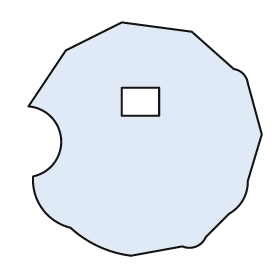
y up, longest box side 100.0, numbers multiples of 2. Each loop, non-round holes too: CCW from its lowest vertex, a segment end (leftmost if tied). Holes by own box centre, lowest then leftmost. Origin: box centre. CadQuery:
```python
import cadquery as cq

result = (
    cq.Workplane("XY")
    .moveTo(-6.0, -50.0)
    .lineTo(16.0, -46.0)
    .threePointArc((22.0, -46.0), (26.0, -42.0))
    .lineTo(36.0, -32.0)
    .threePointArc((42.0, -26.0), (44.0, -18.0))
    .lineTo(50.0, 2.0)
    .lineTo(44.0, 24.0)
    .threePointArc((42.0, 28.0), (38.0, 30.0))
    .lineTo(20.0, 46.0)
    .lineTo(-10.0, 50.0)
    .lineTo(-34.0, 38.0)
    .lineTo(-50.0, 14.0)
    .threePointArc((-36.0, 0.0), (-48.0, -16.0))
    .threePointArc((-44.0, -30.0), (-32.0, -38.0))
    .threePointArc((-20.0, -46.0), (-6.0, -50.0))
    .close()
    .moveTo(-10.0, 10.0)
    .lineTo(6.0, 10.0)
    .lineTo(6.0, 22.0)
    .lineTo(-10.0, 22.0)
    .close()
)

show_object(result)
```